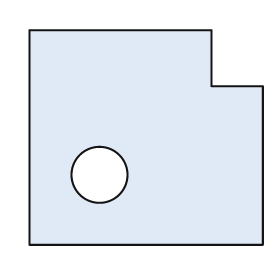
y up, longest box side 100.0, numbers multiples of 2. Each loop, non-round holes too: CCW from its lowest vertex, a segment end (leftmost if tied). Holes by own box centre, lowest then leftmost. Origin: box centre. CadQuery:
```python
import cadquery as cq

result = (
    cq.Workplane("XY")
    .moveTo(-50.0, -46.0)
    .lineTo(50.0, -46.0)
    .lineTo(50.0, 22.0)
    .lineTo(28.0, 22.0)
    .lineTo(28.0, 46.0)
    .lineTo(-50.0, 46.0)
    .close()
    .moveTo(-20.0, -16.0)
    .circle(12.0)
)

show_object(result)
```